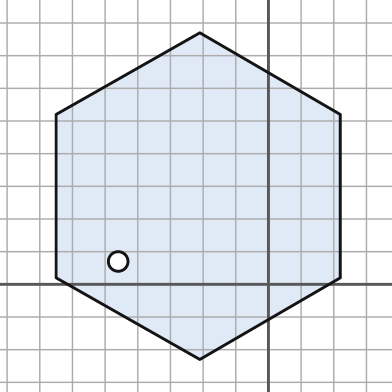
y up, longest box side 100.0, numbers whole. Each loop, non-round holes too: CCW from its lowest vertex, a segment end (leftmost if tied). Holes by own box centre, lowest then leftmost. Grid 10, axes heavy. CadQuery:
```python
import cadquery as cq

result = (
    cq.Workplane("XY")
    .moveTo(-21.0, -23.0)
    .lineTo(22.0, 2.0)
    .lineTo(22.0, 52.0)
    .lineTo(-21.0, 77.0)
    .lineTo(-65.0, 52.0)
    .lineTo(-65.0, 2.0)
    .close()
    .moveTo(-46.0, 7.0)
    .circle(3.0)
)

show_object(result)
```